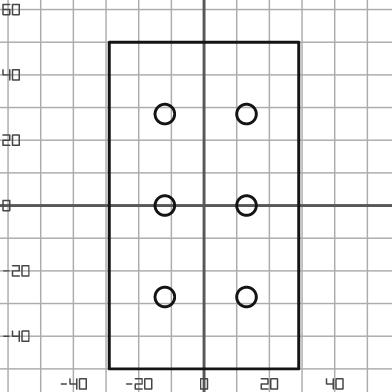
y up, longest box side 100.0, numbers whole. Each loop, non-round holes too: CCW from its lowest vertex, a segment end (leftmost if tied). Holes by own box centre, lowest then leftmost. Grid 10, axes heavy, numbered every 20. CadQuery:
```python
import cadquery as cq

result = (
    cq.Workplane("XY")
    .moveTo(-29.0, -50.0)
    .lineTo(29.0, -50.0)
    .lineTo(29.0, 50.0)
    .lineTo(-29.0, 50.0)
    .close()
    .moveTo(-12.0, -28.0)
    .circle(3.0)
    .moveTo(13.0, -28.0)
    .circle(3.0)
    .moveTo(-12.0, 0.0)
    .circle(3.0)
    .moveTo(13.0, 0.0)
    .circle(3.0)
    .moveTo(-12.0, 28.0)
    .circle(3.0)
    .moveTo(13.0, 28.0)
    .circle(3.0)
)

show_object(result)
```